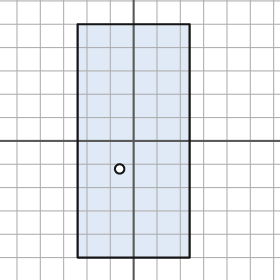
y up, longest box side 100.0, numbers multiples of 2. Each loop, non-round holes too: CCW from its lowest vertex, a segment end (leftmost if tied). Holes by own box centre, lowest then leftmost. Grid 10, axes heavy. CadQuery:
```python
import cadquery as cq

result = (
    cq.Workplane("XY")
    .moveTo(-24.0, -50.0)
    .lineTo(24.0, -50.0)
    .lineTo(24.0, 50.0)
    .lineTo(-24.0, 50.0)
    .close()
    .moveTo(-6.0, -12.0)
    .circle(2.0)
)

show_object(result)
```